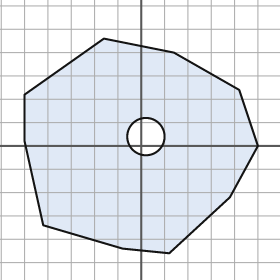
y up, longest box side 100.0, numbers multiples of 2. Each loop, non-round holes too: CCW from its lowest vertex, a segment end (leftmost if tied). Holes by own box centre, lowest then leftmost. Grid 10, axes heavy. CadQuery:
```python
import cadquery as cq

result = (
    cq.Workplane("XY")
    .moveTo(12.0, -46.0)
    .lineTo(38.0, -22.0)
    .lineTo(50.0, 0.0)
    .lineTo(42.0, 24.0)
    .lineTo(14.0, 40.0)
    .lineTo(-16.0, 46.0)
    .lineTo(-50.0, 22.0)
    .lineTo(-50.0, 2.0)
    .lineTo(-42.0, -34.0)
    .lineTo(-8.0, -44.0)
    .close()
    .moveTo(2.0, 4.0)
    .circle(8.0)
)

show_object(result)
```